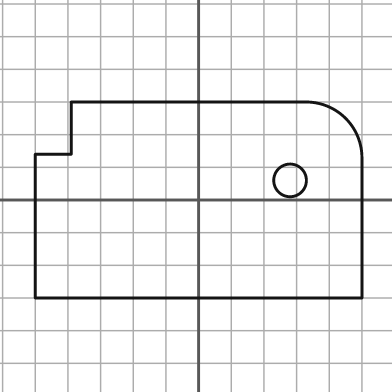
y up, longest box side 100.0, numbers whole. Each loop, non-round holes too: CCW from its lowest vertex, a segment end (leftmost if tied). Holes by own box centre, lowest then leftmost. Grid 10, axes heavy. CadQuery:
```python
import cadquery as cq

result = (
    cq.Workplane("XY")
    .moveTo(-50.0, -30.0)
    .lineTo(50.0, -30.0)
    .lineTo(50.0, 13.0)
    .threePointArc((45.0, 25.0), (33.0, 30.0))
    .lineTo(-39.0, 30.0)
    .lineTo(-39.0, 14.0)
    .lineTo(-50.0, 14.0)
    .close()
    .moveTo(28.0, 6.0)
    .circle(5.0)
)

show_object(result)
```